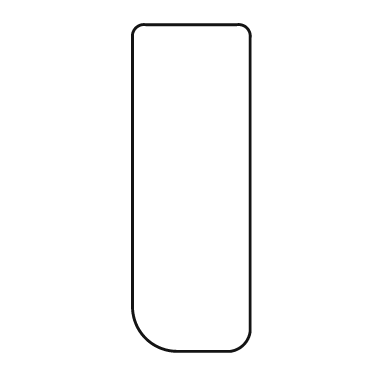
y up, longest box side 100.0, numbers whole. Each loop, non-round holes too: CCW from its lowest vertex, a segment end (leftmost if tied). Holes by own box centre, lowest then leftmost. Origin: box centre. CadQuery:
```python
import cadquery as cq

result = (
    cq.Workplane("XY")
    .moveTo(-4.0, -50.0)
    .lineTo(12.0, -50.0)
    .threePointArc((16.0, -48.0), (18.0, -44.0))
    .lineTo(18.0, 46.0)
    .threePointArc((17.0, 49.0), (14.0, 50.0))
    .lineTo(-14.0, 50.0)
    .threePointArc((-17.0, 49.0), (-18.0, 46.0))
    .lineTo(-18.0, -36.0)
    .threePointArc((-14.0, -46.0), (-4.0, -50.0))
    .close()
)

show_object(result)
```